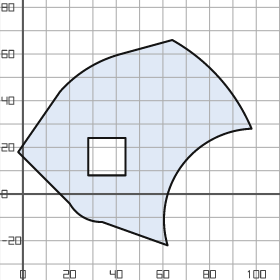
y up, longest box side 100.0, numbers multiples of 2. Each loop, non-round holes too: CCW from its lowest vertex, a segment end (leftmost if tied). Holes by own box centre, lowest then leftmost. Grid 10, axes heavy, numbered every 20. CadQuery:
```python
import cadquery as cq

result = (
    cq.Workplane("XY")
    .moveTo(62.0, -22.0)
    .threePointArc((68.0, 12.0), (98.0, 28.0))
    .threePointArc((84.0, 50.0), (64.0, 66.0))
    .lineTo(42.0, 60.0)
    .threePointArc((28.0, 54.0), (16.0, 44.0))
    .lineTo(-2.0, 18.0)
    .lineTo(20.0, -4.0)
    .threePointArc((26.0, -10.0), (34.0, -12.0))
    .close()
    .moveTo(28.0, 8.0)
    .lineTo(44.0, 8.0)
    .lineTo(44.0, 24.0)
    .lineTo(28.0, 24.0)
    .close()
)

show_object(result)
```